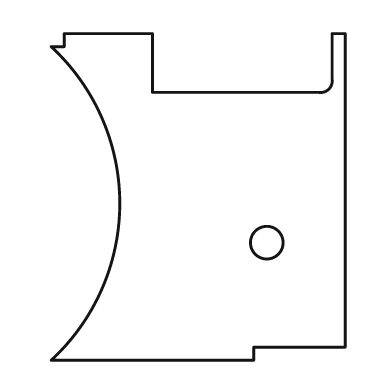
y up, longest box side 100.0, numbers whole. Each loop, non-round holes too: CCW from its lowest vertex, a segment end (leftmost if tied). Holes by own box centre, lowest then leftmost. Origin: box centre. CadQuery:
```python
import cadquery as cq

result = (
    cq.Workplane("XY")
    .moveTo(-45.0, -50.0)
    .lineTo(17.0, -50.0)
    .lineTo(17.0, -46.0)
    .lineTo(45.0, -46.0)
    .lineTo(45.0, 50.0)
    .lineTo(41.0, 50.0)
    .lineTo(41.0, 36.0)
    .threePointArc((40.0, 33.0), (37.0, 32.0))
    .lineTo(-14.0, 32.0)
    .lineTo(-14.0, 50.0)
    .lineTo(-41.0, 50.0)
    .lineTo(-41.0, 46.0)
    .lineTo(-45.0, 46.0)
    .threePointArc((-24.0, -2.0), (-45.0, -50.0))
    .close()
    .moveTo(21.0, -14.0)
    .circle(5.0)
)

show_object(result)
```